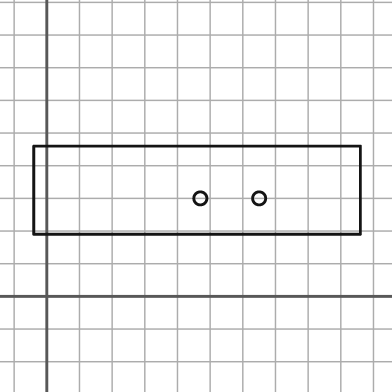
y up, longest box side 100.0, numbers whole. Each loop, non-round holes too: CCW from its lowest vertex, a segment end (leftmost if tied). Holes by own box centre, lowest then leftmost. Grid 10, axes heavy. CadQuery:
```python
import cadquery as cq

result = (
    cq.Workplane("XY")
    .moveTo(-4.0, 19.0)
    .lineTo(96.0, 19.0)
    .lineTo(96.0, 46.0)
    .lineTo(-4.0, 46.0)
    .close()
    .moveTo(47.0, 30.0)
    .circle(2.0)
    .moveTo(65.0, 30.0)
    .circle(2.0)
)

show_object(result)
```